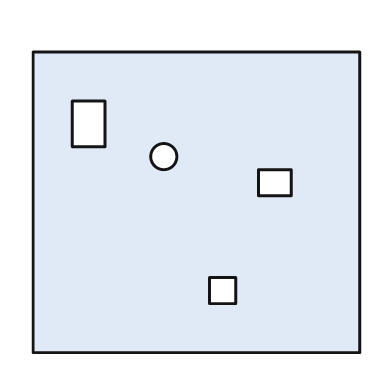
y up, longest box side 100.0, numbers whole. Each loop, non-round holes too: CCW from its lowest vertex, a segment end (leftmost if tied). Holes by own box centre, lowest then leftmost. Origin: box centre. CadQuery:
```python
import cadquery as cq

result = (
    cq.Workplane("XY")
    .moveTo(-50.0, -46.0)
    .lineTo(50.0, -46.0)
    .lineTo(50.0, 46.0)
    .lineTo(-50.0, 46.0)
    .close()
    .moveTo(4.0, -31.0)
    .lineTo(12.0, -31.0)
    .lineTo(12.0, -23.0)
    .lineTo(4.0, -23.0)
    .close()
    .moveTo(19.0, 2.0)
    .lineTo(29.0, 2.0)
    .lineTo(29.0, 10.0)
    .lineTo(19.0, 10.0)
    .close()
    .moveTo(-10.0, 14.0)
    .circle(4.0)
    .moveTo(-38.0, 17.0)
    .lineTo(-28.0, 17.0)
    .lineTo(-28.0, 31.0)
    .lineTo(-38.0, 31.0)
    .close()
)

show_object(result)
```